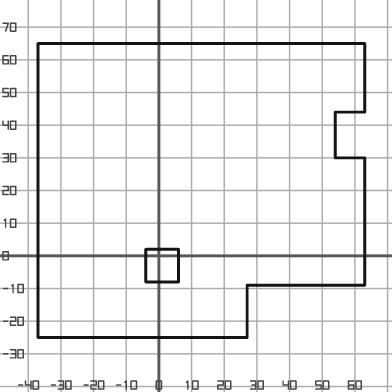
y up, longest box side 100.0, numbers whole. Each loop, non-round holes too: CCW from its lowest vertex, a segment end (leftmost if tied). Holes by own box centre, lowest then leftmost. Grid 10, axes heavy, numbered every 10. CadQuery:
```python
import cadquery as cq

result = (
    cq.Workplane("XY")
    .moveTo(-37.0, -25.0)
    .lineTo(27.0, -25.0)
    .lineTo(27.0, -9.0)
    .lineTo(63.0, -9.0)
    .lineTo(63.0, 30.0)
    .lineTo(54.0, 30.0)
    .lineTo(54.0, 44.0)
    .lineTo(63.0, 44.0)
    .lineTo(63.0, 65.0)
    .lineTo(-37.0, 65.0)
    .close()
    .moveTo(-4.0, -8.0)
    .lineTo(6.0, -8.0)
    .lineTo(6.0, 2.0)
    .lineTo(-4.0, 2.0)
    .close()
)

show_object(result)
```